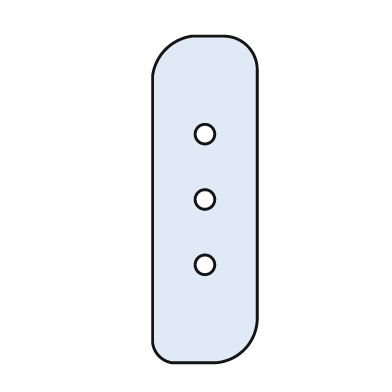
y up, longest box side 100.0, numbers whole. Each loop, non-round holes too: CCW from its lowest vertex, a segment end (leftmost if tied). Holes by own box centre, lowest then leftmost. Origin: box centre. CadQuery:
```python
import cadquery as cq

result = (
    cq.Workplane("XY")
    .moveTo(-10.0, -50.0)
    .lineTo(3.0, -50.0)
    .threePointArc((12.0, -46.0), (16.0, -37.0))
    .lineTo(16.0, 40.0)
    .threePointArc((13.0, 47.0), (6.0, 50.0))
    .lineTo(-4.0, 50.0)
    .threePointArc((-12.0, 46.0), (-16.0, 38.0))
    .lineTo(-16.0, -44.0)
    .threePointArc((-14.0, -48.0), (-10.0, -50.0))
    .close()
    .moveTo(0.0, -20.0)
    .circle(3.0)
    .moveTo(0.0, 0.0)
    .circle(3.0)
    .moveTo(0.0, 20.0)
    .circle(3.0)
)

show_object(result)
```